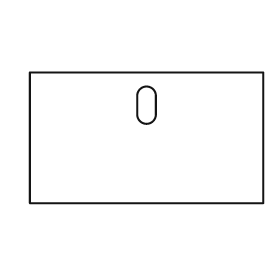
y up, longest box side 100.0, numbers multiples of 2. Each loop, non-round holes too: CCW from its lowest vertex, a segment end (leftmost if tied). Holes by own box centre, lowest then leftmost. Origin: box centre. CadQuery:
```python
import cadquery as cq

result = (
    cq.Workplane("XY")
    .moveTo(-50.0, -28.0)
    .lineTo(50.0, -28.0)
    .lineTo(50.0, 28.0)
    .lineTo(-50.0, 28.0)
    .close()
    .moveTo(-4.0, 10.0)
    .threePointArc((0.0, 6.0), (4.0, 10.0))
    .lineTo(4.0, 18.0)
    .threePointArc((0.0, 22.0), (-4.0, 18.0))
    .close()
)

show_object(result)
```